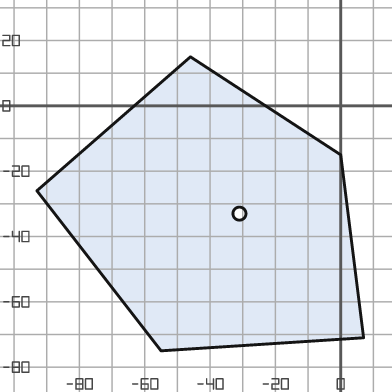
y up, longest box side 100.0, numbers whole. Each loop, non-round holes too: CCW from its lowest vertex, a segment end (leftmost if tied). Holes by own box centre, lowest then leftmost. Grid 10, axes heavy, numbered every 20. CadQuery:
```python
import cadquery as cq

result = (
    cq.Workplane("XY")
    .moveTo(-55.0, -75.0)
    .lineTo(7.0, -71.0)
    .lineTo(0.0, -15.0)
    .lineTo(-46.0, 15.0)
    .lineTo(-93.0, -26.0)
    .close()
    .moveTo(-31.0, -33.0)
    .circle(2.0)
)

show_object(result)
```